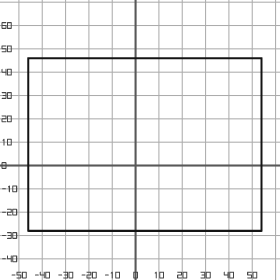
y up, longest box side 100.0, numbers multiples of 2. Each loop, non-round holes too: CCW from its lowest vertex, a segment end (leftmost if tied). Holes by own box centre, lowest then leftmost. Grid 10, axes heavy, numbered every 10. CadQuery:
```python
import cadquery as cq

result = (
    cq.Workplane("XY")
    .moveTo(-46.0, -28.0)
    .lineTo(54.0, -28.0)
    .lineTo(54.0, 46.0)
    .lineTo(-46.0, 46.0)
    .close()
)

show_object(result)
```